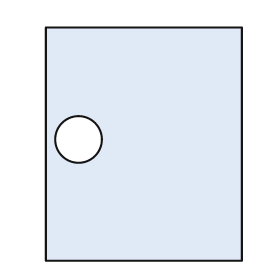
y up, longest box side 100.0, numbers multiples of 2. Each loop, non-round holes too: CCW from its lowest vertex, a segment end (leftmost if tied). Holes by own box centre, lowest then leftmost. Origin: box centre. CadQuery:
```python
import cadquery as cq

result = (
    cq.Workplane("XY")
    .moveTo(-42.0, -50.0)
    .lineTo(42.0, -50.0)
    .lineTo(42.0, 50.0)
    .lineTo(-42.0, 50.0)
    .close()
    .moveTo(-28.0, 2.0)
    .circle(10.0)
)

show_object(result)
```